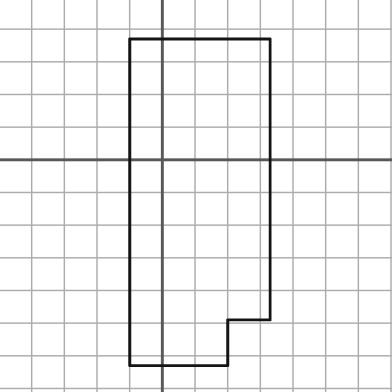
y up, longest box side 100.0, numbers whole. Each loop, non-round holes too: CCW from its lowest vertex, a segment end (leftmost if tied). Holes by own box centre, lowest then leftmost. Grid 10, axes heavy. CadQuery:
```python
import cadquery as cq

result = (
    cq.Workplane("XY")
    .moveTo(-10.0, -63.0)
    .lineTo(20.0, -63.0)
    .lineTo(20.0, -49.0)
    .lineTo(33.0, -49.0)
    .lineTo(33.0, 37.0)
    .lineTo(-10.0, 37.0)
    .close()
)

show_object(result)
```